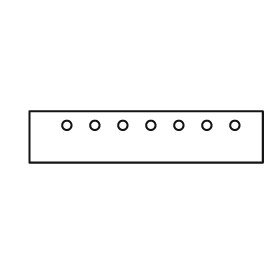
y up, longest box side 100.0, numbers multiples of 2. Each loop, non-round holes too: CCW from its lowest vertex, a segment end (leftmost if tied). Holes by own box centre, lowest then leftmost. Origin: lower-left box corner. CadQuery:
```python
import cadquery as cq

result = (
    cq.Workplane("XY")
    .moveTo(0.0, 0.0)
    .lineTo(100.0, 0.0)
    .lineTo(100.0, 22.0)
    .lineTo(0.0, 22.0)
    .close()
    .moveTo(16.0, 16.0)
    .circle(2.0)
    .moveTo(28.0, 16.0)
    .circle(2.0)
    .moveTo(40.0, 16.0)
    .circle(2.0)
    .moveTo(52.0, 16.0)
    .circle(2.0)
    .moveTo(64.0, 16.0)
    .circle(2.0)
    .moveTo(76.0, 16.0)
    .circle(2.0)
    .moveTo(88.0, 16.0)
    .circle(2.0)
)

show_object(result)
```